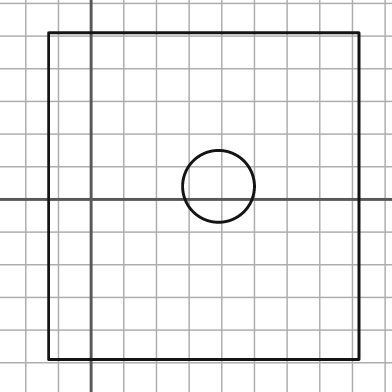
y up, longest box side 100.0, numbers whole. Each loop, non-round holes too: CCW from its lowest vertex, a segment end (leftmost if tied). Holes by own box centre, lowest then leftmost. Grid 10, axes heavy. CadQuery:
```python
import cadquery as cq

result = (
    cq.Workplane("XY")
    .moveTo(-13.0, -49.0)
    .lineTo(82.0, -49.0)
    .lineTo(82.0, 51.0)
    .lineTo(-13.0, 51.0)
    .close()
    .moveTo(39.0, 4.0)
    .circle(11.0)
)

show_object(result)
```